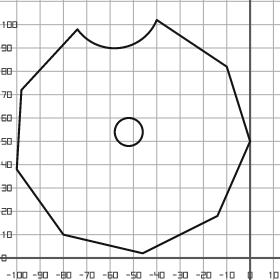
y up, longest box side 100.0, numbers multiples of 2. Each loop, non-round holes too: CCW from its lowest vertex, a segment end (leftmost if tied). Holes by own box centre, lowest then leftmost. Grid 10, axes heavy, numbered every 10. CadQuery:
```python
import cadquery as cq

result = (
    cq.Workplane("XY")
    .moveTo(-46.0, 2.0)
    .lineTo(-14.0, 18.0)
    .lineTo(0.0, 50.0)
    .lineTo(-10.0, 82.0)
    .lineTo(-40.0, 102.0)
    .threePointArc((-56.0, 90.0), (-74.0, 98.0))
    .lineTo(-98.0, 72.0)
    .lineTo(-100.0, 38.0)
    .lineTo(-80.0, 10.0)
    .close()
    .moveTo(-52.0, 54.0)
    .circle(6.0)
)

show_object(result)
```